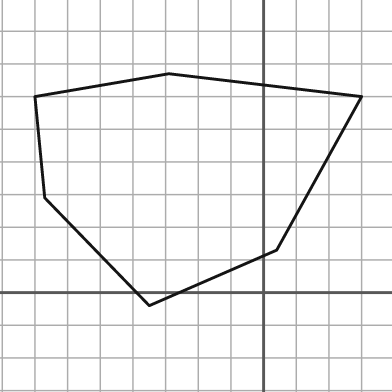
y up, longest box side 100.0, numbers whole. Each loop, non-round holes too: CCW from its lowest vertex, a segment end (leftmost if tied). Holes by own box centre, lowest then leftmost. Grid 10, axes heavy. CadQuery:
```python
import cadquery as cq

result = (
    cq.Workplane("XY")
    .moveTo(-35.0, -4.0)
    .lineTo(4.0, 13.0)
    .lineTo(30.0, 60.0)
    .lineTo(-29.0, 67.0)
    .lineTo(-70.0, 60.0)
    .lineTo(-67.0, 29.0)
    .close()
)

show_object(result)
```